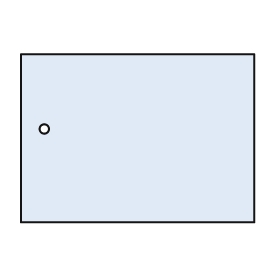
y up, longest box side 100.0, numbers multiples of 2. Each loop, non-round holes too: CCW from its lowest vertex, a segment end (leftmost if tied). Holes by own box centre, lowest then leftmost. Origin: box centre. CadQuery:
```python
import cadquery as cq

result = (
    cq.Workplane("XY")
    .moveTo(-50.0, -36.0)
    .lineTo(50.0, -36.0)
    .lineTo(50.0, 36.0)
    .lineTo(-50.0, 36.0)
    .close()
    .moveTo(-40.0, 4.0)
    .circle(2.0)
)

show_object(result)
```